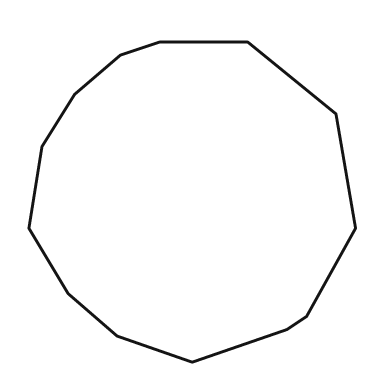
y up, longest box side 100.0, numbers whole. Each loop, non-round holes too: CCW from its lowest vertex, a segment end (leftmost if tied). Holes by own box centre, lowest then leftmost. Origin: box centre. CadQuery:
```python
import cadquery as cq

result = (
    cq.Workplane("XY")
    .moveTo(0.0, -49.0)
    .lineTo(29.0, -39.0)
    .lineTo(35.0, -35.0)
    .lineTo(50.0, -8.0)
    .lineTo(44.0, 27.0)
    .lineTo(17.0, 49.0)
    .lineTo(-10.0, 49.0)
    .lineTo(-22.0, 45.0)
    .lineTo(-36.0, 33.0)
    .lineTo(-46.0, 17.0)
    .lineTo(-50.0, -8.0)
    .lineTo(-38.0, -28.0)
    .lineTo(-23.0, -41.0)
    .close()
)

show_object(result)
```